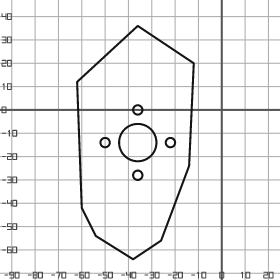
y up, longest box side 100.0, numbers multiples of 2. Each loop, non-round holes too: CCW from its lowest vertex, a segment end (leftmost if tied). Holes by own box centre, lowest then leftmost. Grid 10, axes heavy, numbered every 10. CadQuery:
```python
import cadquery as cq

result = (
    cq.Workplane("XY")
    .moveTo(-38.0, -64.0)
    .lineTo(-26.0, -56.0)
    .lineTo(-14.0, -24.0)
    .lineTo(-12.0, 20.0)
    .lineTo(-36.0, 36.0)
    .lineTo(-62.0, 12.0)
    .lineTo(-60.0, -42.0)
    .lineTo(-54.0, -54.0)
    .close()
    .moveTo(-36.0, -28.0)
    .circle(2.0)
    .moveTo(-50.0, -14.0)
    .circle(2.0)
    .moveTo(-36.0, -14.0)
    .circle(8.0)
    .moveTo(-22.0, -14.0)
    .circle(2.0)
    .moveTo(-36.0, 0.0)
    .circle(2.0)
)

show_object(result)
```